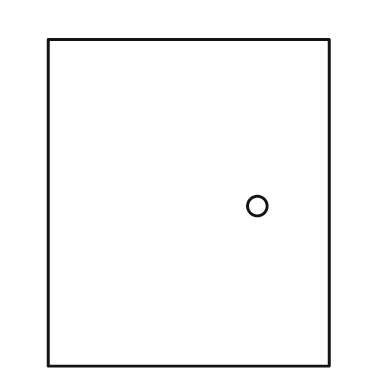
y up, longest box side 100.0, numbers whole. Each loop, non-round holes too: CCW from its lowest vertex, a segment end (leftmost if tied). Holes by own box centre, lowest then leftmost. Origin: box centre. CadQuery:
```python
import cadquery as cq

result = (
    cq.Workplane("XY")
    .moveTo(-43.0, -50.0)
    .lineTo(43.0, -50.0)
    .lineTo(43.0, 50.0)
    .lineTo(-43.0, 50.0)
    .close()
    .moveTo(21.0, -1.0)
    .circle(3.0)
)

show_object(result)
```